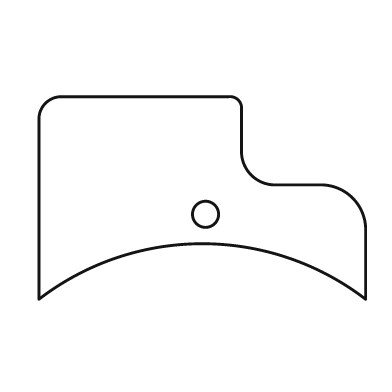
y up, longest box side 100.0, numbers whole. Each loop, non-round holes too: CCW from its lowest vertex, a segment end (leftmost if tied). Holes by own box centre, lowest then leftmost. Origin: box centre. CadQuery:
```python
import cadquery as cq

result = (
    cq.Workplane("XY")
    .moveTo(-50.0, -31.0)
    .threePointArc((0.0, -14.0), (50.0, -31.0))
    .lineTo(50.0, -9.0)
    .threePointArc((46.0, 0.0), (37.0, 4.0))
    .lineTo(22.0, 4.0)
    .threePointArc((15.0, 7.0), (12.0, 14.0))
    .lineTo(12.0, 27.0)
    .threePointArc((11.0, 30.0), (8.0, 31.0))
    .lineTo(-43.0, 31.0)
    .threePointArc((-48.0, 29.0), (-50.0, 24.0))
    .close()
    .moveTo(1.0, -5.0)
    .circle(4.0)
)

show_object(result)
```